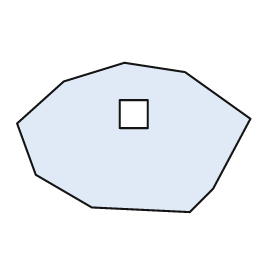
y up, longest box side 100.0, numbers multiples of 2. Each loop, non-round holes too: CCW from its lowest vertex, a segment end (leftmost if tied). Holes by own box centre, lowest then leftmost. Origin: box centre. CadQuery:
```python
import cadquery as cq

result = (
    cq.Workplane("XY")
    .moveTo(24.0, -32.0)
    .lineTo(34.0, -22.0)
    .lineTo(50.0, 8.0)
    .lineTo(22.0, 28.0)
    .lineTo(-4.0, 32.0)
    .lineTo(-30.0, 24.0)
    .lineTo(-50.0, 6.0)
    .lineTo(-42.0, -16.0)
    .lineTo(-18.0, -30.0)
    .close()
    .moveTo(-6.0, 4.0)
    .lineTo(6.0, 4.0)
    .lineTo(6.0, 16.0)
    .lineTo(-6.0, 16.0)
    .close()
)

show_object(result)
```